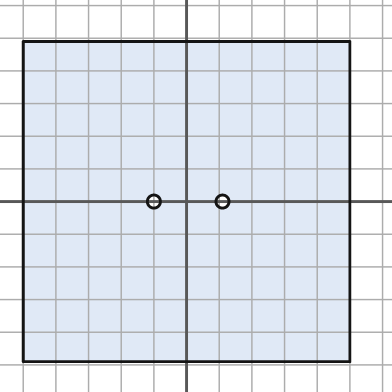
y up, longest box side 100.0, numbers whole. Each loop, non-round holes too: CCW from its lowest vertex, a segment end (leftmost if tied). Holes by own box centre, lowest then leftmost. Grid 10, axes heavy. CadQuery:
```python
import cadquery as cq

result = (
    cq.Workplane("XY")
    .moveTo(-50.0, -49.0)
    .lineTo(50.0, -49.0)
    .lineTo(50.0, 49.0)
    .lineTo(-50.0, 49.0)
    .close()
    .moveTo(-10.0, 0.0)
    .circle(2.0)
    .moveTo(11.0, 0.0)
    .circle(2.0)
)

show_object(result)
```